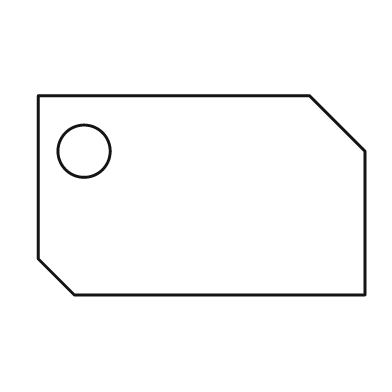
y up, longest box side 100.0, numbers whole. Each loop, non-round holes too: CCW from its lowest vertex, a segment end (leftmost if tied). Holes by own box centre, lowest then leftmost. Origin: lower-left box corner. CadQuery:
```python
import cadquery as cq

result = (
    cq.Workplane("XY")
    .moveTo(11.0, 0.0)
    .lineTo(100.0, 0.0)
    .lineTo(100.0, 44.0)
    .lineTo(83.0, 61.0)
    .lineTo(0.0, 61.0)
    .lineTo(0.0, 11.0)
    .close()
    .moveTo(14.0, 44.0)
    .circle(8.0)
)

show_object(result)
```